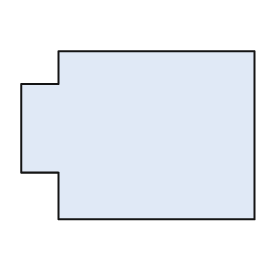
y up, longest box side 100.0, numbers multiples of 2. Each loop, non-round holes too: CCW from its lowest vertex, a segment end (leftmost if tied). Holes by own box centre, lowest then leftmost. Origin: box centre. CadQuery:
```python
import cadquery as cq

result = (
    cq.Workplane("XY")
    .moveTo(-34.0, -36.0)
    .lineTo(50.0, -36.0)
    .lineTo(50.0, 36.0)
    .lineTo(-34.0, 36.0)
    .lineTo(-34.0, 22.0)
    .lineTo(-50.0, 22.0)
    .lineTo(-50.0, -16.0)
    .lineTo(-34.0, -16.0)
    .close()
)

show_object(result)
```